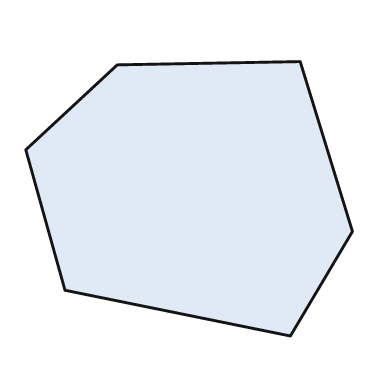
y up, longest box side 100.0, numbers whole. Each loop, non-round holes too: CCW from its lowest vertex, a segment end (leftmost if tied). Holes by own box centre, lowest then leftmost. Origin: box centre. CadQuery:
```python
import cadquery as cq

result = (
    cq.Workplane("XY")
    .moveTo(31.0, -42.0)
    .lineTo(50.0, -10.0)
    .lineTo(34.0, 42.0)
    .lineTo(-22.0, 41.0)
    .lineTo(-50.0, 15.0)
    .lineTo(-38.0, -28.0)
    .close()
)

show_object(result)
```